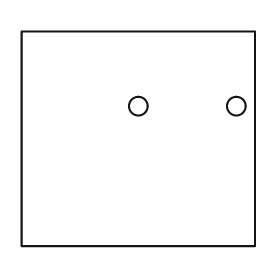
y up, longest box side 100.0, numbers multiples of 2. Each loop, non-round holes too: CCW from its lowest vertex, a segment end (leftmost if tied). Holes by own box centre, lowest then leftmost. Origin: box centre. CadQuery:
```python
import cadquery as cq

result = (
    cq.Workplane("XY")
    .moveTo(-50.0, -46.0)
    .lineTo(50.0, -46.0)
    .lineTo(50.0, 46.0)
    .lineTo(-50.0, 46.0)
    .close()
    .moveTo(0.0, 14.0)
    .circle(4.0)
    .moveTo(42.0, 14.0)
    .circle(4.0)
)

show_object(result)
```